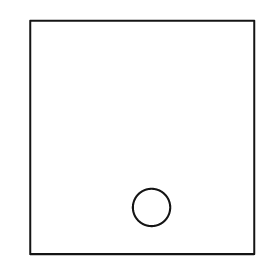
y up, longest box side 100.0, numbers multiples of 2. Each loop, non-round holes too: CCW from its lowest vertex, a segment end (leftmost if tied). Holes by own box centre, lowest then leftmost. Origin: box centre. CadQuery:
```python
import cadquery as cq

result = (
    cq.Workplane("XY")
    .moveTo(-48.0, -50.0)
    .lineTo(48.0, -50.0)
    .lineTo(48.0, 50.0)
    .lineTo(-48.0, 50.0)
    .close()
    .moveTo(4.0, -30.0)
    .circle(8.0)
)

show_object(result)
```